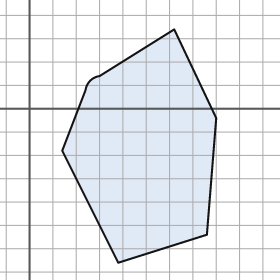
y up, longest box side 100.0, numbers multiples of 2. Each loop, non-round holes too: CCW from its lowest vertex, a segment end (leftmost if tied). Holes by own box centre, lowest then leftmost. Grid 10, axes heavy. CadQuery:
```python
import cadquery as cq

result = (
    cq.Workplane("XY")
    .moveTo(38.0, -66.0)
    .lineTo(76.0, -54.0)
    .lineTo(80.0, -4.0)
    .lineTo(62.0, 34.0)
    .lineTo(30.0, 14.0)
    .threePointArc((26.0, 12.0), (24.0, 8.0))
    .lineTo(14.0, -18.0)
    .close()
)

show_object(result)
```